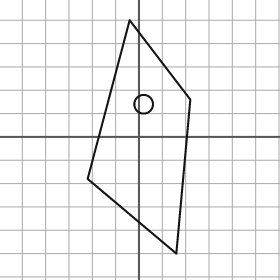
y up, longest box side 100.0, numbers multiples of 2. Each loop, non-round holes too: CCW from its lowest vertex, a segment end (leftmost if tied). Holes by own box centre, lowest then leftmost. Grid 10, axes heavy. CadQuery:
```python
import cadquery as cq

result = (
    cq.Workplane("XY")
    .moveTo(16.0, -50.0)
    .lineTo(22.0, 16.0)
    .lineTo(-4.0, 50.0)
    .lineTo(-22.0, -18.0)
    .close()
    .moveTo(2.0, 14.0)
    .circle(4.0)
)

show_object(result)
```